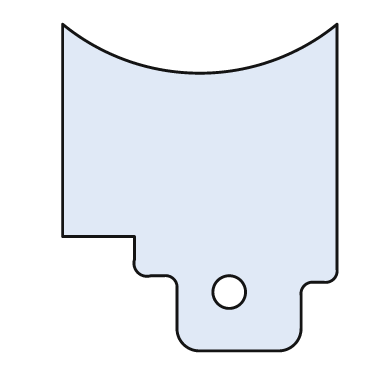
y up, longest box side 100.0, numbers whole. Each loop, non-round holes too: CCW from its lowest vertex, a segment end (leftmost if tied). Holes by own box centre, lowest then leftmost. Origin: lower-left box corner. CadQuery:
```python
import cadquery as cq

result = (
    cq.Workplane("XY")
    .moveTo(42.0, 0.0)
    .lineTo(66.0, 0.0)
    .threePointArc((71.0, 2.0), (73.0, 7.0))
    .lineTo(73.0, 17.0)
    .threePointArc((74.0, 20.0), (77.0, 21.0))
    .lineTo(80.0, 21.0)
    .threePointArc((83.0, 22.0), (84.0, 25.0))
    .lineTo(84.0, 100.0)
    .threePointArc((42.0, 85.0), (0.0, 100.0))
    .lineTo(0.0, 35.0)
    .lineTo(22.0, 35.0)
    .lineTo(22.0, 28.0)
    .threePointArc((23.0, 24.0), (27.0, 23.0))
    .lineTo(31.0, 23.0)
    .threePointArc((34.0, 22.0), (35.0, 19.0))
    .lineTo(35.0, 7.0)
    .threePointArc((37.0, 2.0), (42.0, 0.0))
    .close()
    .moveTo(51.0, 18.0)
    .circle(5.0)
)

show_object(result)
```